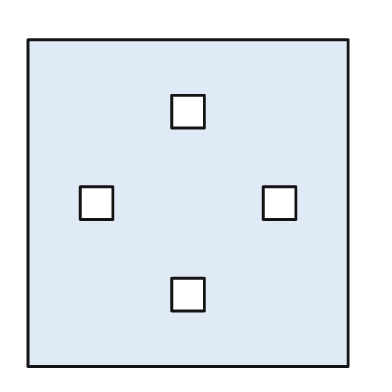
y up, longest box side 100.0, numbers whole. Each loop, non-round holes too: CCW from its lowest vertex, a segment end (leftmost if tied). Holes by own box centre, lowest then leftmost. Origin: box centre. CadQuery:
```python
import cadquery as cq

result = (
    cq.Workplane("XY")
    .moveTo(-49.0, -50.0)
    .lineTo(49.0, -50.0)
    .lineTo(49.0, 50.0)
    .lineTo(-49.0, 50.0)
    .close()
    .moveTo(-5.0, -33.0)
    .lineTo(5.0, -33.0)
    .lineTo(5.0, -23.0)
    .lineTo(-5.0, -23.0)
    .close()
    .moveTo(-33.0, -5.0)
    .lineTo(-23.0, -5.0)
    .lineTo(-23.0, 5.0)
    .lineTo(-33.0, 5.0)
    .close()
    .moveTo(23.0, -5.0)
    .lineTo(33.0, -5.0)
    .lineTo(33.0, 5.0)
    .lineTo(23.0, 5.0)
    .close()
    .moveTo(-5.0, 23.0)
    .lineTo(5.0, 23.0)
    .lineTo(5.0, 33.0)
    .lineTo(-5.0, 33.0)
    .close()
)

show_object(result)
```